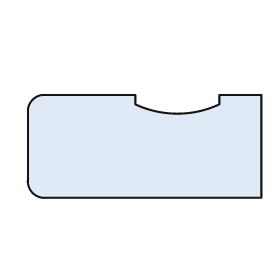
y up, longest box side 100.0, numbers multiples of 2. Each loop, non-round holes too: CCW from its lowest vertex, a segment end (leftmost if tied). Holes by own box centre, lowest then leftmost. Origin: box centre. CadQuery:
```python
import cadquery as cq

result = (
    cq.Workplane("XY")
    .moveTo(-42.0, -22.0)
    .lineTo(50.0, -22.0)
    .lineTo(50.0, 22.0)
    .lineTo(32.0, 22.0)
    .lineTo(32.0, 18.0)
    .threePointArc((14.0, 14.0), (-4.0, 18.0))
    .lineTo(-4.0, 22.0)
    .lineTo(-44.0, 22.0)
    .threePointArc((-48.0, 20.0), (-50.0, 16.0))
    .lineTo(-50.0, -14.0)
    .threePointArc((-48.0, -20.0), (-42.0, -22.0))
    .close()
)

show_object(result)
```